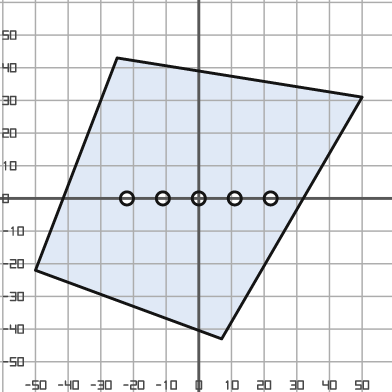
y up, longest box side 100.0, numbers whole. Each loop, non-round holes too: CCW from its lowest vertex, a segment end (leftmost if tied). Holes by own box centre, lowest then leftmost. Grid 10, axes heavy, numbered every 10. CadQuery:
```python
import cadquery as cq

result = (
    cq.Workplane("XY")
    .moveTo(7.0, -43.0)
    .lineTo(50.0, 31.0)
    .lineTo(-25.0, 43.0)
    .lineTo(-50.0, -22.0)
    .close()
    .moveTo(-22.0, 0.0)
    .circle(2.0)
    .moveTo(-11.0, 0.0)
    .circle(2.0)
    .moveTo(0.0, 0.0)
    .circle(2.0)
    .moveTo(11.0, 0.0)
    .circle(2.0)
    .moveTo(22.0, 0.0)
    .circle(2.0)
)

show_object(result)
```